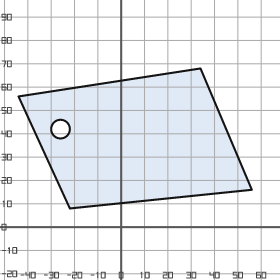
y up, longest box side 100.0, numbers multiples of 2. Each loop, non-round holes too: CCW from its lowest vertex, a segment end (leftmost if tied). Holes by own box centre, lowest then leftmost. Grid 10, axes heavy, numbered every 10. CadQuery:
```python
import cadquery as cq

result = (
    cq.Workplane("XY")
    .moveTo(-22.0, 8.0)
    .lineTo(56.0, 16.0)
    .lineTo(34.0, 68.0)
    .lineTo(-44.0, 56.0)
    .close()
    .moveTo(-26.0, 42.0)
    .circle(4.0)
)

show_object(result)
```